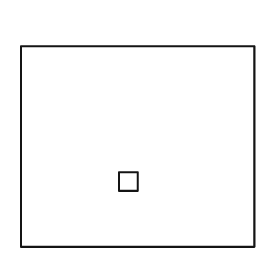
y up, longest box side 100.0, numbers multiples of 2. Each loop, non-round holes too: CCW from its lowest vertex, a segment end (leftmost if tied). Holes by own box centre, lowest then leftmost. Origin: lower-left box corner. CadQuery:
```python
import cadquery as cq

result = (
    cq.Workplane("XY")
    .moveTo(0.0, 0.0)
    .lineTo(100.0, 0.0)
    .lineTo(100.0, 86.0)
    .lineTo(0.0, 86.0)
    .close()
    .moveTo(42.0, 24.0)
    .lineTo(50.0, 24.0)
    .lineTo(50.0, 32.0)
    .lineTo(42.0, 32.0)
    .close()
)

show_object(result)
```